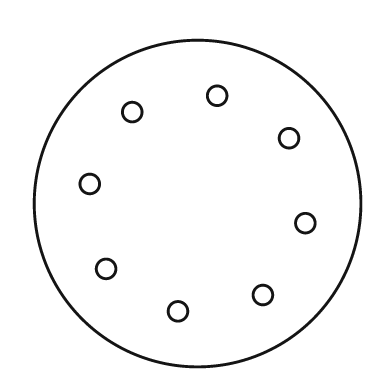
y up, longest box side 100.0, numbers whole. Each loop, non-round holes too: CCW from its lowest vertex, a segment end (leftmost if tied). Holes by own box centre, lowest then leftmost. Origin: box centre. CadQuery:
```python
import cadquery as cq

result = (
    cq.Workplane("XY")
    .moveTo(0.0, 0.0)
    .circle(50.0)
    .moveTo(-6.0, -33.0)
    .circle(3.0)
    .moveTo(20.0, -28.0)
    .circle(3.0)
    .moveTo(-28.0, -20.0)
    .circle(3.0)
    .moveTo(33.0, -6.0)
    .circle(3.0)
    .moveTo(-33.0, 6.0)
    .circle(3.0)
    .moveTo(28.0, 20.0)
    .circle(3.0)
    .moveTo(-20.0, 28.0)
    .circle(3.0)
    .moveTo(6.0, 33.0)
    .circle(3.0)
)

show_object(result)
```